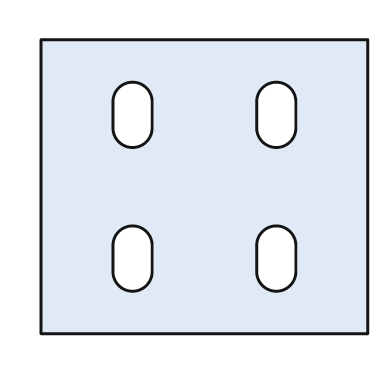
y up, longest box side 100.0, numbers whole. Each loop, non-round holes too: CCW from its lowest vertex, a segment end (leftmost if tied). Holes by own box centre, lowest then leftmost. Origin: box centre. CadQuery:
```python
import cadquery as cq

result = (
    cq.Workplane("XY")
    .moveTo(-50.0, -45.0)
    .lineTo(50.0, -45.0)
    .lineTo(50.0, 45.0)
    .lineTo(-50.0, 45.0)
    .close()
    .moveTo(-28.0, -26.0)
    .threePointArc((-22.0, -32.0), (-16.0, -26.0))
    .lineTo(-16.0, -18.0)
    .threePointArc((-22.0, -12.0), (-28.0, -18.0))
    .close()
    .moveTo(16.0, -26.0)
    .threePointArc((22.0, -32.0), (28.0, -26.0))
    .lineTo(28.0, -18.0)
    .threePointArc((22.0, -12.0), (16.0, -18.0))
    .close()
    .moveTo(-28.0, 18.0)
    .threePointArc((-22.0, 12.0), (-16.0, 18.0))
    .lineTo(-16.0, 26.0)
    .threePointArc((-22.0, 32.0), (-28.0, 26.0))
    .close()
    .moveTo(16.0, 18.0)
    .threePointArc((22.0, 12.0), (28.0, 18.0))
    .lineTo(28.0, 26.0)
    .threePointArc((22.0, 32.0), (16.0, 26.0))
    .close()
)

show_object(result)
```